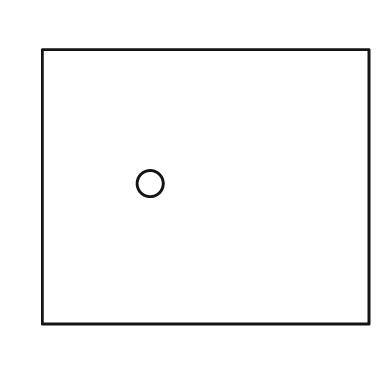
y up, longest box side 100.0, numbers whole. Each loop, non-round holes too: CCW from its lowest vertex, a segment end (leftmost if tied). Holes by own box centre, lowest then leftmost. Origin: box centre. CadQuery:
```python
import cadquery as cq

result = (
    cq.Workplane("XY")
    .moveTo(-50.0, -42.0)
    .lineTo(50.0, -42.0)
    .lineTo(50.0, 42.0)
    .lineTo(-50.0, 42.0)
    .close()
    .moveTo(-17.0, 1.0)
    .circle(4.0)
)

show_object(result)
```